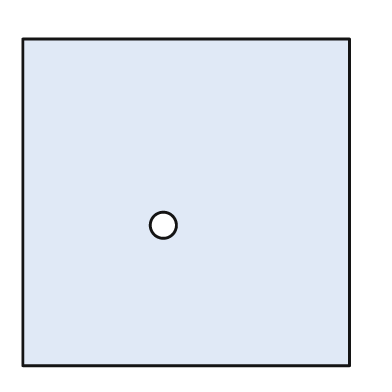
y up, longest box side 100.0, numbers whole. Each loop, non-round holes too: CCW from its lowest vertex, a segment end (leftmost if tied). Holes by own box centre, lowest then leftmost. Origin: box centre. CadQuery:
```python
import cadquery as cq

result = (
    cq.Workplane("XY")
    .moveTo(-50.0, -50.0)
    .lineTo(50.0, -50.0)
    .lineTo(50.0, 50.0)
    .lineTo(-50.0, 50.0)
    .close()
    .moveTo(-7.0, -7.0)
    .circle(4.0)
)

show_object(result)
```